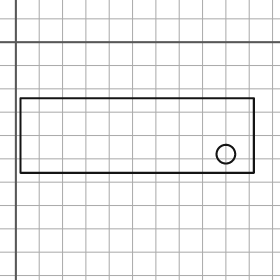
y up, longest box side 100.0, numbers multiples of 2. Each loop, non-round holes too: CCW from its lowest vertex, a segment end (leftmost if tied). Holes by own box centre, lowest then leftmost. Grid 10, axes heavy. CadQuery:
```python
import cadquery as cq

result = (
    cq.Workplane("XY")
    .moveTo(2.0, -56.0)
    .lineTo(102.0, -56.0)
    .lineTo(102.0, -24.0)
    .lineTo(2.0, -24.0)
    .close()
    .moveTo(90.0, -48.0)
    .circle(4.0)
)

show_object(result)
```